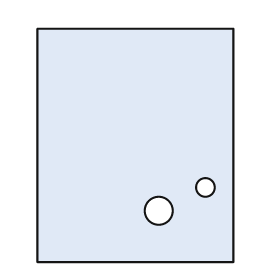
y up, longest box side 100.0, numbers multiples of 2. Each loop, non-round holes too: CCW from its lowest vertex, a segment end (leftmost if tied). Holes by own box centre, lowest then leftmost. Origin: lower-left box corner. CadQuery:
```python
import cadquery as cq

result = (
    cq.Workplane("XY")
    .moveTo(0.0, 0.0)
    .lineTo(84.0, 0.0)
    .lineTo(84.0, 100.0)
    .lineTo(0.0, 100.0)
    .close()
    .moveTo(52.0, 22.0)
    .circle(6.0)
    .moveTo(72.0, 32.0)
    .circle(4.0)
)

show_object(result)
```